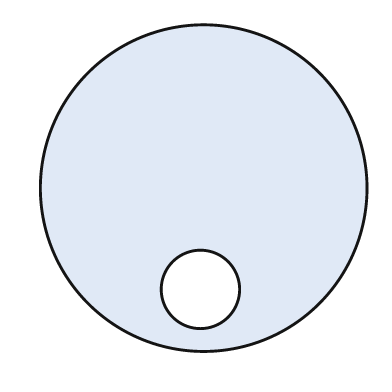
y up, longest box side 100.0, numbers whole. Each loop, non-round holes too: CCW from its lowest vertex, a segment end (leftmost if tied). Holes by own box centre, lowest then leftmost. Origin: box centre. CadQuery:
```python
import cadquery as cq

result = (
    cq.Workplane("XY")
    .moveTo(0.0, 0.0)
    .circle(50.0)
    .moveTo(-1.0, -31.0)
    .circle(12.0)
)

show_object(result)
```